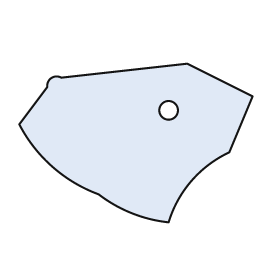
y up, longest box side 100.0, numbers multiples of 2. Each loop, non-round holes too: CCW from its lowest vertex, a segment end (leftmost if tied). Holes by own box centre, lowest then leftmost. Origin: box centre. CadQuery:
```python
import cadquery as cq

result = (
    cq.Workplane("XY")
    .moveTo(14.0, -34.0)
    .threePointArc((24.0, -16.0), (40.0, -4.0))
    .lineTo(50.0, 20.0)
    .lineTo(22.0, 34.0)
    .lineTo(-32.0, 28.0)
    .threePointArc((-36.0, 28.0), (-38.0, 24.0))
    .lineTo(-50.0, 8.0)
    .threePointArc((-36.0, -10.0), (-16.0, -22.0))
    .threePointArc((-2.0, -30.0), (14.0, -34.0))
    .close()
    .moveTo(14.0, 14.0)
    .circle(4.0)
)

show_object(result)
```